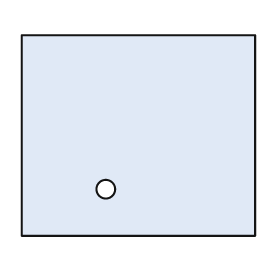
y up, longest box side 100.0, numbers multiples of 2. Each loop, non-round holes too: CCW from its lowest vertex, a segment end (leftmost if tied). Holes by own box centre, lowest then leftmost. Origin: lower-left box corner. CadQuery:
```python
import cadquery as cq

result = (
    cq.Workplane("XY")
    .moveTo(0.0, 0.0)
    .lineTo(100.0, 0.0)
    .lineTo(100.0, 86.0)
    .lineTo(0.0, 86.0)
    .close()
    .moveTo(36.0, 20.0)
    .circle(4.0)
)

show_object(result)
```